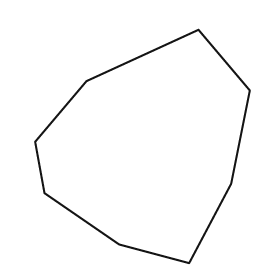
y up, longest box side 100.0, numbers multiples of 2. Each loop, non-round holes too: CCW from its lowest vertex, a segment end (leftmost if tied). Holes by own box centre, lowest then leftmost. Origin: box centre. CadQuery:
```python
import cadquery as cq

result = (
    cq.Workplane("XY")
    .moveTo(20.0, -50.0)
    .lineTo(38.0, -16.0)
    .lineTo(46.0, 24.0)
    .lineTo(24.0, 50.0)
    .lineTo(-24.0, 28.0)
    .lineTo(-46.0, 2.0)
    .lineTo(-42.0, -20.0)
    .lineTo(-10.0, -42.0)
    .close()
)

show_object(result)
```